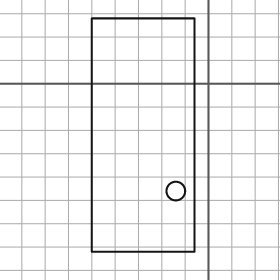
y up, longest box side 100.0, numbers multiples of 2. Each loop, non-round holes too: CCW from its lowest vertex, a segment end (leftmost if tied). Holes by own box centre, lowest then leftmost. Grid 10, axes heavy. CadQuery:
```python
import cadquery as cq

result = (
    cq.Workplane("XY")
    .moveTo(-50.0, -72.0)
    .lineTo(-6.0, -72.0)
    .lineTo(-6.0, 28.0)
    .lineTo(-50.0, 28.0)
    .close()
    .moveTo(-14.0, -46.0)
    .circle(4.0)
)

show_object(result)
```